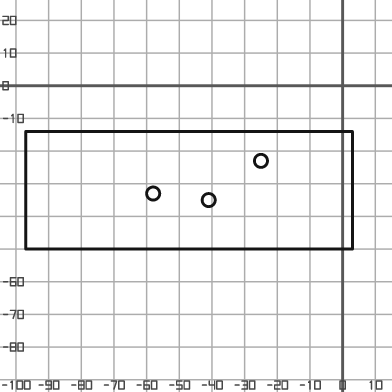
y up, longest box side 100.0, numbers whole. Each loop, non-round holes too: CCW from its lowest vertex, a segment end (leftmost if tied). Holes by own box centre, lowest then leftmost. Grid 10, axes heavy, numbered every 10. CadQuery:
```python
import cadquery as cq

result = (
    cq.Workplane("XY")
    .moveTo(-97.0, -50.0)
    .lineTo(3.0, -50.0)
    .lineTo(3.0, -14.0)
    .lineTo(-97.0, -14.0)
    .close()
    .moveTo(-41.0, -35.0)
    .circle(2.0)
    .moveTo(-58.0, -33.0)
    .circle(2.0)
    .moveTo(-25.0, -23.0)
    .circle(2.0)
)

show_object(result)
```